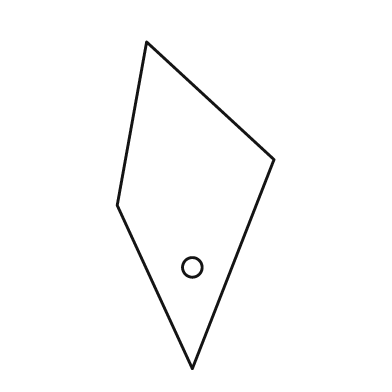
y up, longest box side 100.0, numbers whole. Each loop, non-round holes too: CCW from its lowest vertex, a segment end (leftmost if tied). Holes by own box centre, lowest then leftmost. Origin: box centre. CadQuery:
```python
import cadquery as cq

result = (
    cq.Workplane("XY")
    .moveTo(-1.0, -50.0)
    .lineTo(24.0, 14.0)
    .lineTo(-15.0, 50.0)
    .lineTo(-24.0, 0.0)
    .close()
    .moveTo(-1.0, -19.0)
    .circle(3.0)
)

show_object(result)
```